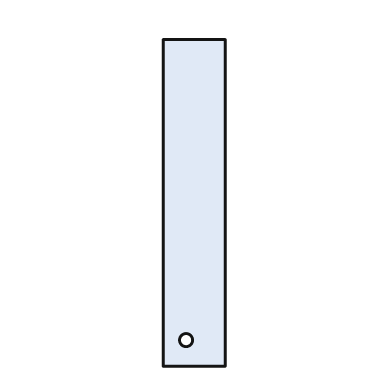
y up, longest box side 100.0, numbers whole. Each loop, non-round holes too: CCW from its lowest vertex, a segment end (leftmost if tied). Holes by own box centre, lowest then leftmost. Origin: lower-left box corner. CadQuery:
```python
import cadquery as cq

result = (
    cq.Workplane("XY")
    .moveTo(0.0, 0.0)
    .lineTo(19.0, 0.0)
    .lineTo(19.0, 100.0)
    .lineTo(0.0, 100.0)
    .close()
    .moveTo(7.0, 8.0)
    .circle(2.0)
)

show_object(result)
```